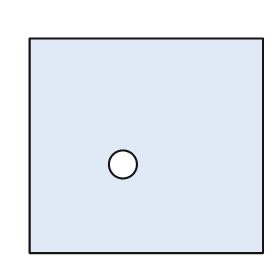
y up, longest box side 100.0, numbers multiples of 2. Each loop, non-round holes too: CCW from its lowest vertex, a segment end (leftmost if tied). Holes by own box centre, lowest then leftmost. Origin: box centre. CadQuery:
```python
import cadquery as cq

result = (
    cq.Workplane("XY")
    .moveTo(-50.0, -46.0)
    .lineTo(50.0, -46.0)
    .lineTo(50.0, 46.0)
    .lineTo(-50.0, 46.0)
    .close()
    .moveTo(-10.0, -8.0)
    .circle(6.0)
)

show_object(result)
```